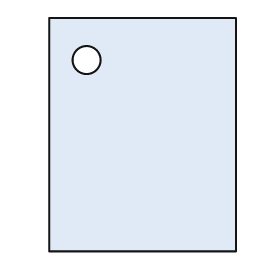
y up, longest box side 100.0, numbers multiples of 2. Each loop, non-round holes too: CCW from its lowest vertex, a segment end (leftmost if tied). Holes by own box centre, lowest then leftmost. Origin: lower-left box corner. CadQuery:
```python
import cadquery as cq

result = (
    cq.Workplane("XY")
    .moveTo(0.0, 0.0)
    .lineTo(80.0, 0.0)
    .lineTo(80.0, 100.0)
    .lineTo(0.0, 100.0)
    .close()
    .moveTo(16.0, 82.0)
    .circle(6.0)
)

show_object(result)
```